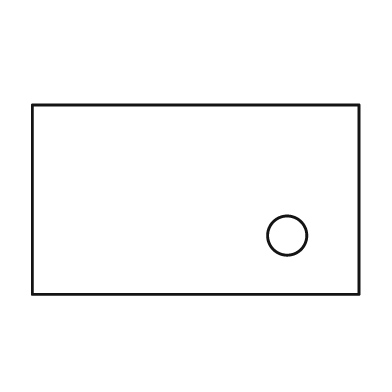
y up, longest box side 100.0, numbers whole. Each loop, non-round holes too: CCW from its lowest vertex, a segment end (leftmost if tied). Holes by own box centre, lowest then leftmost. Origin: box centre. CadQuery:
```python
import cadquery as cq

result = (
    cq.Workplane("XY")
    .moveTo(-50.0, -29.0)
    .lineTo(50.0, -29.0)
    .lineTo(50.0, 29.0)
    .lineTo(-50.0, 29.0)
    .close()
    .moveTo(28.0, -11.0)
    .circle(6.0)
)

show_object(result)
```